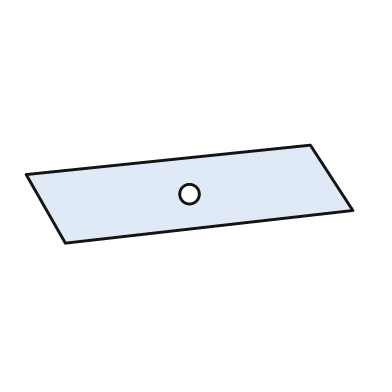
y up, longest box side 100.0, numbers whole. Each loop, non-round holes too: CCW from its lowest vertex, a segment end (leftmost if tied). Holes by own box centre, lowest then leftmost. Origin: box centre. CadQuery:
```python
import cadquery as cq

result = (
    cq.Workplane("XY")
    .moveTo(-38.0, -15.0)
    .lineTo(50.0, -5.0)
    .lineTo(37.0, 15.0)
    .lineTo(-50.0, 6.0)
    .close()
    .moveTo(0.0, 0.0)
    .circle(3.0)
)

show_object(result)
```